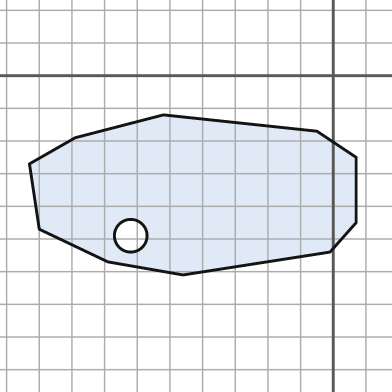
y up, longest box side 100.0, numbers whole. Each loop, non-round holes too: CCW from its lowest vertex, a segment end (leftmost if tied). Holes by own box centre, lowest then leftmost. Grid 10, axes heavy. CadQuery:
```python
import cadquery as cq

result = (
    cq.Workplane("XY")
    .moveTo(-46.0, -61.0)
    .lineTo(-1.0, -54.0)
    .lineTo(7.0, -45.0)
    .lineTo(7.0, -25.0)
    .lineTo(-5.0, -17.0)
    .lineTo(-52.0, -12.0)
    .lineTo(-79.0, -19.0)
    .lineTo(-93.0, -27.0)
    .lineTo(-90.0, -47.0)
    .lineTo(-69.0, -57.0)
    .close()
    .moveTo(-62.0, -49.0)
    .circle(5.0)
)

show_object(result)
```